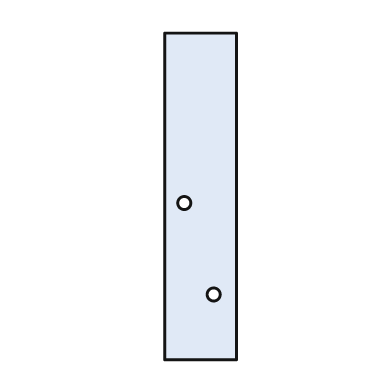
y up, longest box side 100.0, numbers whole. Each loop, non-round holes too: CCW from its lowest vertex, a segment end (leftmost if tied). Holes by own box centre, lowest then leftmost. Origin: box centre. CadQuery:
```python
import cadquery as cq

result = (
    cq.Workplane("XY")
    .moveTo(-11.0, -50.0)
    .lineTo(11.0, -50.0)
    .lineTo(11.0, 50.0)
    .lineTo(-11.0, 50.0)
    .close()
    .moveTo(4.0, -30.0)
    .circle(2.0)
    .moveTo(-5.0, -2.0)
    .circle(2.0)
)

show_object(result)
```